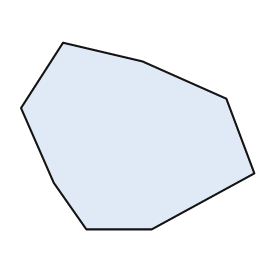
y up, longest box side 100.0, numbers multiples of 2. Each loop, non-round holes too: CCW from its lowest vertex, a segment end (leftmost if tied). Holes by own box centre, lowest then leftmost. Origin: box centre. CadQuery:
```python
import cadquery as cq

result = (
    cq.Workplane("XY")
    .moveTo(-22.0, -40.0)
    .lineTo(6.0, -40.0)
    .lineTo(50.0, -16.0)
    .lineTo(38.0, 16.0)
    .lineTo(2.0, 32.0)
    .lineTo(-32.0, 40.0)
    .lineTo(-50.0, 12.0)
    .lineTo(-36.0, -20.0)
    .close()
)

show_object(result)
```